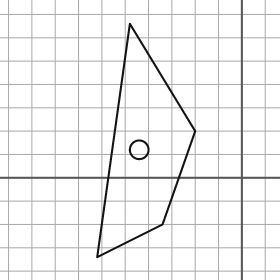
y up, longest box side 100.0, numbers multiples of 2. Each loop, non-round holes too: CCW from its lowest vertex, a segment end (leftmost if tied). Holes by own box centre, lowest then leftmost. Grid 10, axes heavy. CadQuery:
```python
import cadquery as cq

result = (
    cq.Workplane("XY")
    .moveTo(-62.0, -34.0)
    .lineTo(-34.0, -20.0)
    .lineTo(-20.0, 20.0)
    .lineTo(-48.0, 66.0)
    .close()
    .moveTo(-44.0, 12.0)
    .circle(4.0)
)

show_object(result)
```